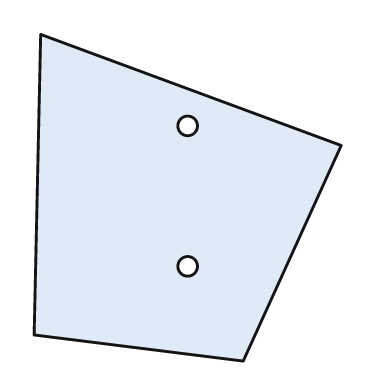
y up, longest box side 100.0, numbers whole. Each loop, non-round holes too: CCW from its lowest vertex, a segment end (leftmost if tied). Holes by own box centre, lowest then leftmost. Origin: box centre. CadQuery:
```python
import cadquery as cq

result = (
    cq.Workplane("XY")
    .moveTo(17.0, -50.0)
    .lineTo(47.0, 16.0)
    .lineTo(-45.0, 50.0)
    .lineTo(-47.0, -42.0)
    .close()
    .moveTo(0.0, -21.0)
    .circle(3.0)
    .moveTo(0.0, 22.0)
    .circle(3.0)
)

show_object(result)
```